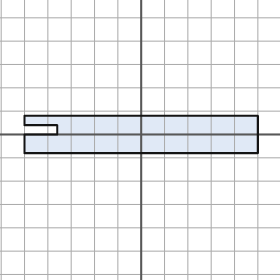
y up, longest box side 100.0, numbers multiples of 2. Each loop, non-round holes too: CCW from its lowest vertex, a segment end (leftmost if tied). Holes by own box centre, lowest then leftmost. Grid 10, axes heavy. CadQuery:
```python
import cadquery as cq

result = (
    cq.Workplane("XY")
    .moveTo(-50.0, -8.0)
    .lineTo(50.0, -8.0)
    .lineTo(50.0, 8.0)
    .lineTo(-50.0, 8.0)
    .lineTo(-50.0, 4.0)
    .lineTo(-36.0, 4.0)
    .lineTo(-36.0, 0.0)
    .lineTo(-50.0, 0.0)
    .close()
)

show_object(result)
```